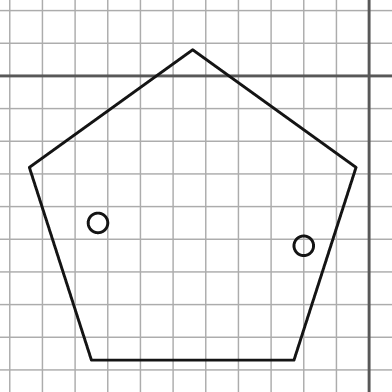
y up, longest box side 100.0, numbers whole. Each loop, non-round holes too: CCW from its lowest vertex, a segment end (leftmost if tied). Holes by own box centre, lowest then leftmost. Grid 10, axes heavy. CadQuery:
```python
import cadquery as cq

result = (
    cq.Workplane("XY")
    .moveTo(-85.0, -87.0)
    .lineTo(-23.0, -87.0)
    .lineTo(-4.0, -28.0)
    .lineTo(-54.0, 8.0)
    .lineTo(-104.0, -28.0)
    .close()
    .moveTo(-20.0, -52.0)
    .circle(3.0)
    .moveTo(-83.0, -45.0)
    .circle(3.0)
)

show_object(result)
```